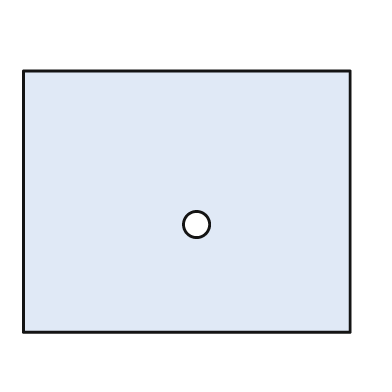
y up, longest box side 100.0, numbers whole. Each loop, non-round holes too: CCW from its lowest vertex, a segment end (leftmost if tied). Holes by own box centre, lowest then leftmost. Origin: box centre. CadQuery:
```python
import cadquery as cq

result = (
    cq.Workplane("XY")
    .moveTo(-50.0, -40.0)
    .lineTo(50.0, -40.0)
    .lineTo(50.0, 40.0)
    .lineTo(-50.0, 40.0)
    .close()
    .moveTo(3.0, -7.0)
    .circle(4.0)
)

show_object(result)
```